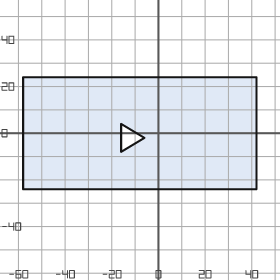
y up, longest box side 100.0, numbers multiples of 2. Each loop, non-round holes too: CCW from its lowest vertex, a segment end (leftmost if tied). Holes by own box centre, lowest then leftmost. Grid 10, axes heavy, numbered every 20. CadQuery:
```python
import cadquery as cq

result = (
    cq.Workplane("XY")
    .moveTo(-58.0, -24.0)
    .lineTo(42.0, -24.0)
    .lineTo(42.0, 24.0)
    .lineTo(-58.0, 24.0)
    .close()
    .moveTo(-16.0, -8.0)
    .lineTo(-6.0, -2.0)
    .lineTo(-16.0, 4.0)
    .close()
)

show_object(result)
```